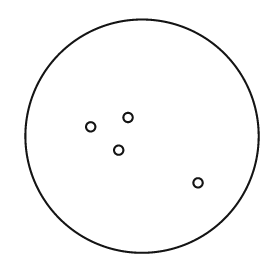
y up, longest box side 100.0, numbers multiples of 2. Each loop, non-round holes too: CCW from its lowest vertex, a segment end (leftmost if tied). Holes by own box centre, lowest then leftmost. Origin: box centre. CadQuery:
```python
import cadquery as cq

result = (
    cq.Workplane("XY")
    .moveTo(0.0, 0.0)
    .circle(50.0)
    .moveTo(24.0, -20.0)
    .circle(2.0)
    .moveTo(-10.0, -6.0)
    .circle(2.0)
    .moveTo(-22.0, 4.0)
    .circle(2.0)
    .moveTo(-6.0, 8.0)
    .circle(2.0)
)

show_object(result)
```